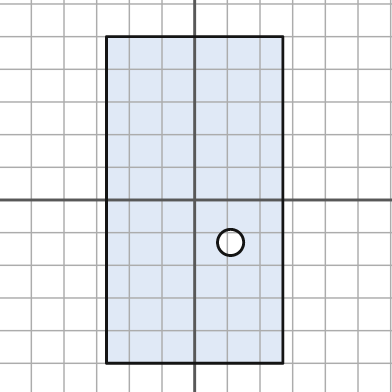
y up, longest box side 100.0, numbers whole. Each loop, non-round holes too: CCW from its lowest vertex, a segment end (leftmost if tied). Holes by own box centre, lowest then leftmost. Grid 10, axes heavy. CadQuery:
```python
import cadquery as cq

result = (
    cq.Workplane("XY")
    .moveTo(-27.0, -50.0)
    .lineTo(27.0, -50.0)
    .lineTo(27.0, 50.0)
    .lineTo(-27.0, 50.0)
    .close()
    .moveTo(11.0, -13.0)
    .circle(4.0)
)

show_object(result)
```